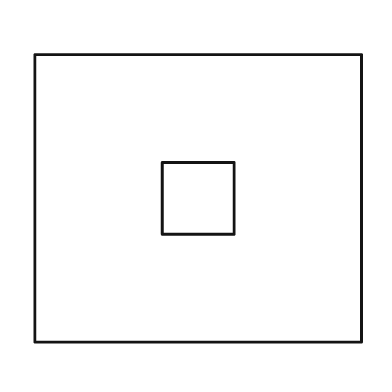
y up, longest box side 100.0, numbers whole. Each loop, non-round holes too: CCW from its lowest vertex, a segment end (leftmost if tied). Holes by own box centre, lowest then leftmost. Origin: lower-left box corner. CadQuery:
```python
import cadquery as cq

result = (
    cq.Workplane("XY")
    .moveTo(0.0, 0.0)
    .lineTo(100.0, 0.0)
    .lineTo(100.0, 88.0)
    .lineTo(0.0, 88.0)
    .close()
    .moveTo(39.0, 33.0)
    .lineTo(61.0, 33.0)
    .lineTo(61.0, 55.0)
    .lineTo(39.0, 55.0)
    .close()
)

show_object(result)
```